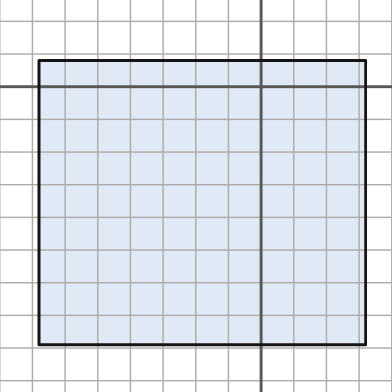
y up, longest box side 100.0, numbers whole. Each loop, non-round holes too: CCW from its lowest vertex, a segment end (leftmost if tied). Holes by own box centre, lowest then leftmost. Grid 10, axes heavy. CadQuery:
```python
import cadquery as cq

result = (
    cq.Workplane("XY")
    .moveTo(-68.0, -79.0)
    .lineTo(32.0, -79.0)
    .lineTo(32.0, 8.0)
    .lineTo(-68.0, 8.0)
    .close()
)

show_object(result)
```